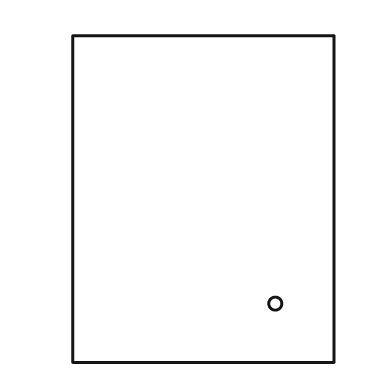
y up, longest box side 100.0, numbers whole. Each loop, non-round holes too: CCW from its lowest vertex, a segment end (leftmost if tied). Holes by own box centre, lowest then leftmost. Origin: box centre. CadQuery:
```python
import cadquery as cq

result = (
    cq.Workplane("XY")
    .moveTo(-40.0, -50.0)
    .lineTo(40.0, -50.0)
    .lineTo(40.0, 50.0)
    .lineTo(-40.0, 50.0)
    .close()
    .moveTo(22.0, -32.0)
    .circle(2.0)
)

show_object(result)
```